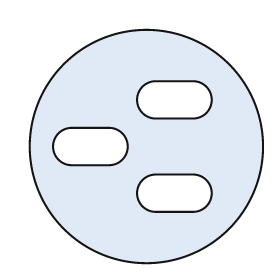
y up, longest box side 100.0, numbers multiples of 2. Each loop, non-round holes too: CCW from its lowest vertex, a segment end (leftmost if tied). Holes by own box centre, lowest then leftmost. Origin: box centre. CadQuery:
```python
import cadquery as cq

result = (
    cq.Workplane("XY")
    .moveTo(0.0, 0.0)
    .circle(50.0)
    .moveTo(4.0, -28.0)
    .lineTo(20.0, -28.0)
    .threePointArc((28.0, -20.0), (20.0, -12.0))
    .lineTo(4.0, -12.0)
    .threePointArc((-4.0, -20.0), (4.0, -28.0))
    .close()
    .moveTo(-32.0, -8.0)
    .lineTo(-16.0, -8.0)
    .threePointArc((-8.0, 0.0), (-16.0, 8.0))
    .lineTo(-32.0, 8.0)
    .threePointArc((-40.0, 0.0), (-32.0, -8.0))
    .close()
    .moveTo(4.0, 12.0)
    .lineTo(20.0, 12.0)
    .threePointArc((28.0, 20.0), (20.0, 28.0))
    .lineTo(4.0, 28.0)
    .threePointArc((-4.0, 20.0), (4.0, 12.0))
    .close()
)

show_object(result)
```